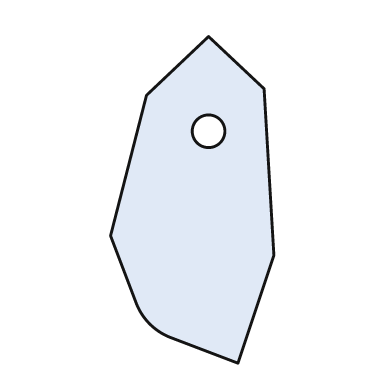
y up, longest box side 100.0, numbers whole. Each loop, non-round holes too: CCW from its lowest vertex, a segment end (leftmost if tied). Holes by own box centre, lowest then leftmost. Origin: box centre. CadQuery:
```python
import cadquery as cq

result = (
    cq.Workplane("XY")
    .moveTo(14.0, -50.0)
    .lineTo(25.0, -17.0)
    .lineTo(22.0, 34.0)
    .lineTo(5.0, 50.0)
    .lineTo(-14.0, 32.0)
    .lineTo(-25.0, -11.0)
    .lineTo(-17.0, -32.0)
    .threePointArc((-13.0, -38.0), (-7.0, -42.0))
    .close()
    .moveTo(5.0, 21.0)
    .circle(5.0)
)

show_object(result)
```